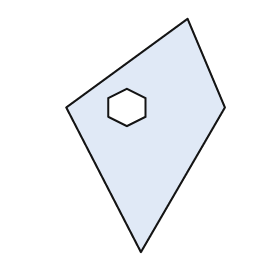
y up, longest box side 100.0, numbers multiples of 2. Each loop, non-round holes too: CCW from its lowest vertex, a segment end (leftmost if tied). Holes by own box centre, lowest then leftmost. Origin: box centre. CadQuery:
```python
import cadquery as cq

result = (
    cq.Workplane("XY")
    .moveTo(-2.0, -50.0)
    .lineTo(34.0, 12.0)
    .lineTo(18.0, 50.0)
    .lineTo(-34.0, 12.0)
    .close()
    .moveTo(-8.0, 4.0)
    .lineTo(0.0, 8.0)
    .lineTo(0.0, 16.0)
    .lineTo(-8.0, 20.0)
    .lineTo(-16.0, 16.0)
    .lineTo(-16.0, 8.0)
    .close()
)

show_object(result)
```